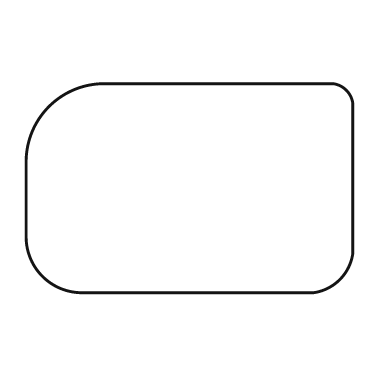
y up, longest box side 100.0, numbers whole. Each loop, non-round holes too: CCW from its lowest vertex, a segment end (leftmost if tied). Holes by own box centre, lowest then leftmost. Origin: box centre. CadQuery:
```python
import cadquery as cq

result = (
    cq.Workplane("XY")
    .moveTo(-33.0, -32.0)
    .lineTo(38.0, -32.0)
    .threePointArc((46.0, -28.0), (50.0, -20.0))
    .lineTo(50.0, 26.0)
    .threePointArc((48.0, 30.0), (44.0, 32.0))
    .lineTo(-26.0, 32.0)
    .threePointArc((-43.0, 25.0), (-50.0, 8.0))
    .lineTo(-50.0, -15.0)
    .threePointArc((-45.0, -27.0), (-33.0, -32.0))
    .close()
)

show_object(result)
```